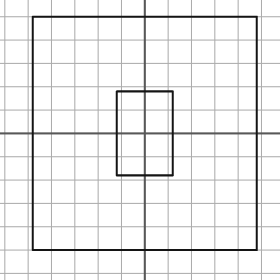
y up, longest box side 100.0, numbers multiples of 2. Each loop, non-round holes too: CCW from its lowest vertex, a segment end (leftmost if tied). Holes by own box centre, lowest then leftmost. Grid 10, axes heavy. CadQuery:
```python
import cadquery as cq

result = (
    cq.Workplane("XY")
    .moveTo(-48.0, -50.0)
    .lineTo(48.0, -50.0)
    .lineTo(48.0, 50.0)
    .lineTo(-48.0, 50.0)
    .close()
    .moveTo(-12.0, -18.0)
    .lineTo(12.0, -18.0)
    .lineTo(12.0, 18.0)
    .lineTo(-12.0, 18.0)
    .close()
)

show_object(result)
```